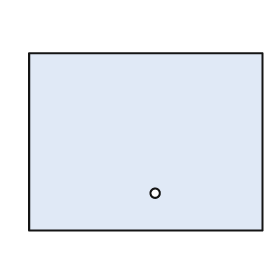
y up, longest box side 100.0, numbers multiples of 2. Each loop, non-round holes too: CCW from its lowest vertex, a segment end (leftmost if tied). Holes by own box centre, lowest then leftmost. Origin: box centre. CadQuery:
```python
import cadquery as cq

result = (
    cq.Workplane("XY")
    .moveTo(-50.0, -38.0)
    .lineTo(50.0, -38.0)
    .lineTo(50.0, 38.0)
    .lineTo(-50.0, 38.0)
    .close()
    .moveTo(4.0, -22.0)
    .circle(2.0)
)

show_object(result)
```